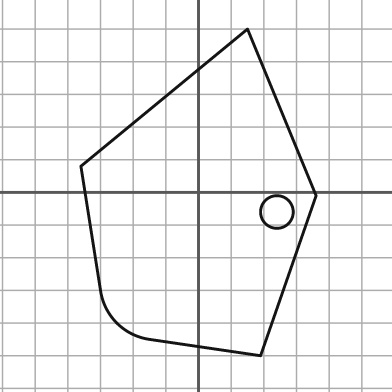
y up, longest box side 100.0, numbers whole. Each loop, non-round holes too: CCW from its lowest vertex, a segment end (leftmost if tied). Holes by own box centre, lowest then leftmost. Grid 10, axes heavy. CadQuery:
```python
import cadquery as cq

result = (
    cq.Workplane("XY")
    .moveTo(19.0, -50.0)
    .lineTo(36.0, -1.0)
    .lineTo(15.0, 50.0)
    .lineTo(-36.0, 8.0)
    .lineTo(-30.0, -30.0)
    .threePointArc((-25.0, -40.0), (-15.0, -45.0))
    .close()
    .moveTo(24.0, -6.0)
    .circle(5.0)
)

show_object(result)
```